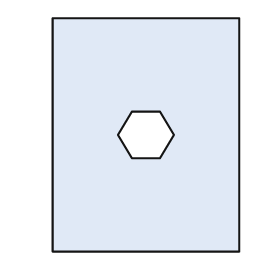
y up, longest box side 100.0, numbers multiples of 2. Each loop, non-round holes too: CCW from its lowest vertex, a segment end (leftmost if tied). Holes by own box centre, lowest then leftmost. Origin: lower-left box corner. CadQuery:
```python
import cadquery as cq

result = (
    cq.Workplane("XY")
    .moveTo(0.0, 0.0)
    .lineTo(80.0, 0.0)
    .lineTo(80.0, 100.0)
    .lineTo(0.0, 100.0)
    .close()
    .moveTo(34.0, 40.0)
    .lineTo(46.0, 40.0)
    .lineTo(52.0, 50.0)
    .lineTo(46.0, 60.0)
    .lineTo(34.0, 60.0)
    .lineTo(28.0, 50.0)
    .close()
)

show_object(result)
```